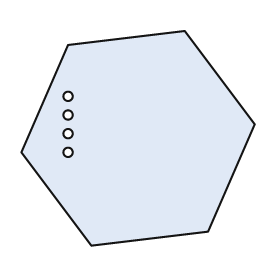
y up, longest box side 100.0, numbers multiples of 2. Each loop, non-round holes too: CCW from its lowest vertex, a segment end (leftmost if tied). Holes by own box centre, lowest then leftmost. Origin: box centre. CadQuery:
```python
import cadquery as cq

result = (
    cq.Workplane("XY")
    .moveTo(-20.0, -46.0)
    .lineTo(30.0, -40.0)
    .lineTo(50.0, 6.0)
    .lineTo(20.0, 46.0)
    .lineTo(-30.0, 40.0)
    .lineTo(-50.0, -6.0)
    .close()
    .moveTo(-30.0, -6.0)
    .circle(2.0)
    .moveTo(-30.0, 2.0)
    .circle(2.0)
    .moveTo(-30.0, 10.0)
    .circle(2.0)
    .moveTo(-30.0, 18.0)
    .circle(2.0)
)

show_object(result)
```